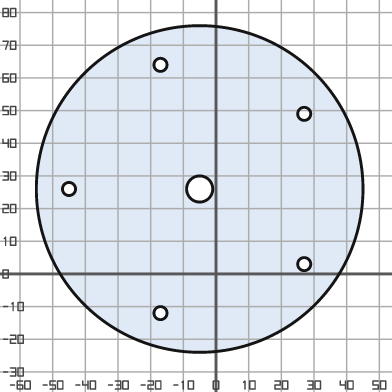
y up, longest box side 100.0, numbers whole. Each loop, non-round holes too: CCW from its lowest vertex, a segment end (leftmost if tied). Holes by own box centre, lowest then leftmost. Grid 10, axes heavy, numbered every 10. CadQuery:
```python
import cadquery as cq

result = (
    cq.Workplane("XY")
    .moveTo(-5.0, 26.0)
    .circle(50.0)
    .moveTo(-17.0, -12.0)
    .circle(2.0)
    .moveTo(27.0, 3.0)
    .circle(2.0)
    .moveTo(-45.0, 26.0)
    .circle(2.0)
    .moveTo(-5.0, 26.0)
    .circle(4.0)
    .moveTo(27.0, 49.0)
    .circle(2.0)
    .moveTo(-17.0, 64.0)
    .circle(2.0)
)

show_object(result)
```